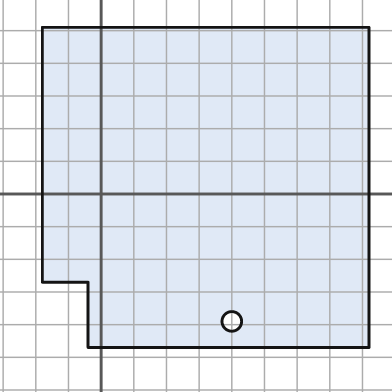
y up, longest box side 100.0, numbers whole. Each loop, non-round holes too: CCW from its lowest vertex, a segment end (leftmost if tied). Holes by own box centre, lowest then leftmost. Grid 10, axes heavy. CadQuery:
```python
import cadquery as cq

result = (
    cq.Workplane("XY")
    .moveTo(-4.0, -47.0)
    .lineTo(82.0, -47.0)
    .lineTo(82.0, 51.0)
    .lineTo(-18.0, 51.0)
    .lineTo(-18.0, -27.0)
    .lineTo(-4.0, -27.0)
    .close()
    .moveTo(40.0, -39.0)
    .circle(3.0)
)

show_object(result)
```